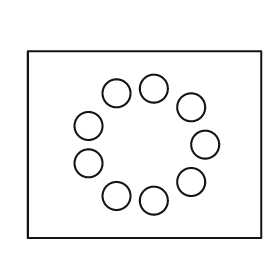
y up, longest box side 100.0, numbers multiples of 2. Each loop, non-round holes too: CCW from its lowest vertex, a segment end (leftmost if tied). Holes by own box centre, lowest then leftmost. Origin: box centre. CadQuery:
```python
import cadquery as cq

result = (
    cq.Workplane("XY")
    .moveTo(-50.0, -40.0)
    .lineTo(50.0, -40.0)
    .lineTo(50.0, 40.0)
    .lineTo(-50.0, 40.0)
    .close()
    .moveTo(4.0, -24.0)
    .circle(6.0)
    .moveTo(-12.0, -22.0)
    .circle(6.0)
    .moveTo(20.0, -16.0)
    .circle(6.0)
    .moveTo(-24.0, -8.0)
    .circle(6.0)
    .moveTo(26.0, 0.0)
    .circle(6.0)
    .moveTo(-24.0, 8.0)
    .circle(6.0)
    .moveTo(20.0, 16.0)
    .circle(6.0)
    .moveTo(-12.0, 22.0)
    .circle(6.0)
    .moveTo(4.0, 24.0)
    .circle(6.0)
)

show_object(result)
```